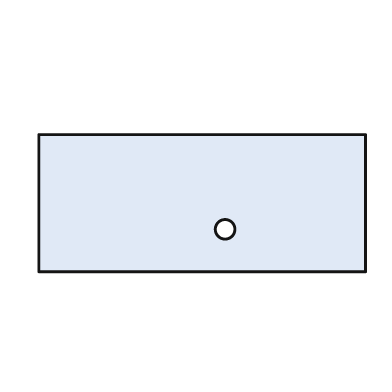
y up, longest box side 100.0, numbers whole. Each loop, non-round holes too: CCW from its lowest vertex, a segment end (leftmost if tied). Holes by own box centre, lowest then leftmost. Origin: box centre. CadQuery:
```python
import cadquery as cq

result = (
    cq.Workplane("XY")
    .moveTo(-50.0, -21.0)
    .lineTo(50.0, -21.0)
    .lineTo(50.0, 21.0)
    .lineTo(-50.0, 21.0)
    .close()
    .moveTo(7.0, -8.0)
    .circle(3.0)
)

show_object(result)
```